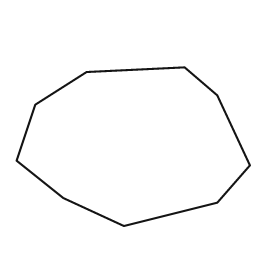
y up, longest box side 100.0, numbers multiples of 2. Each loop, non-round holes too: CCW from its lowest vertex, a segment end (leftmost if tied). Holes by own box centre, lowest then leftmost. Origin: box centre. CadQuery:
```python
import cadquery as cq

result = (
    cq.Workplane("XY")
    .moveTo(-4.0, -34.0)
    .lineTo(36.0, -24.0)
    .lineTo(50.0, -8.0)
    .lineTo(36.0, 22.0)
    .lineTo(22.0, 34.0)
    .lineTo(-20.0, 32.0)
    .lineTo(-42.0, 18.0)
    .lineTo(-50.0, -6.0)
    .lineTo(-30.0, -22.0)
    .close()
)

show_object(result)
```